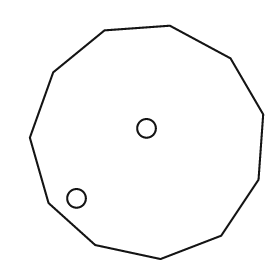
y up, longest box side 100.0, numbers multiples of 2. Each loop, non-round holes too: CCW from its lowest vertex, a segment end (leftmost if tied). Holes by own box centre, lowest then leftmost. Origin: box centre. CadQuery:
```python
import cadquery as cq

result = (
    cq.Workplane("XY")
    .moveTo(6.0, -50.0)
    .lineTo(32.0, -40.0)
    .lineTo(48.0, -16.0)
    .lineTo(50.0, 12.0)
    .lineTo(36.0, 36.0)
    .lineTo(10.0, 50.0)
    .lineTo(-18.0, 48.0)
    .lineTo(-40.0, 30.0)
    .lineTo(-50.0, 2.0)
    .lineTo(-42.0, -26.0)
    .lineTo(-22.0, -44.0)
    .close()
    .moveTo(-30.0, -24.0)
    .circle(4.0)
    .moveTo(0.0, 6.0)
    .circle(4.0)
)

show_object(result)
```